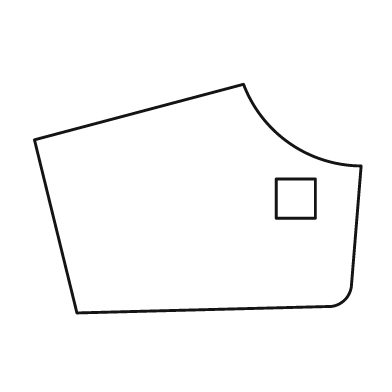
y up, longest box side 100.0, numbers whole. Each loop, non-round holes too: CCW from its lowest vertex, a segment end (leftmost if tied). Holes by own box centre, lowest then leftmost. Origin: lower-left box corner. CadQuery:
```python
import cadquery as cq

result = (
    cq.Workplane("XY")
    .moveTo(13.0, 0.0)
    .lineTo(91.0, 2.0)
    .threePointArc((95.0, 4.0), (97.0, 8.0))
    .lineTo(100.0, 45.0)
    .threePointArc((78.0, 52.0), (64.0, 70.0))
    .lineTo(0.0, 53.0)
    .close()
    .moveTo(74.0, 29.0)
    .lineTo(86.0, 29.0)
    .lineTo(86.0, 41.0)
    .lineTo(74.0, 41.0)
    .close()
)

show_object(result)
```